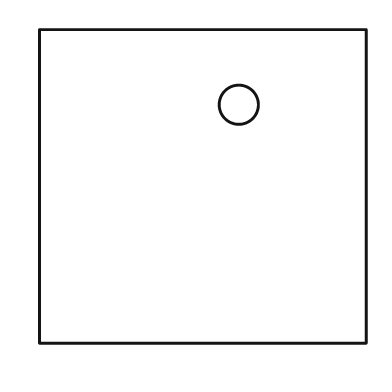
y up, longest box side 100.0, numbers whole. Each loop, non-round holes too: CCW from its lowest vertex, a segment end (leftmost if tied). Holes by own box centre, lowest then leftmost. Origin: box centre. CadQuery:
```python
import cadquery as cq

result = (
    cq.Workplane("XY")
    .moveTo(-50.0, -48.0)
    .lineTo(50.0, -48.0)
    .lineTo(50.0, 48.0)
    .lineTo(-50.0, 48.0)
    .close()
    .moveTo(11.0, 25.0)
    .circle(6.0)
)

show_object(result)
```